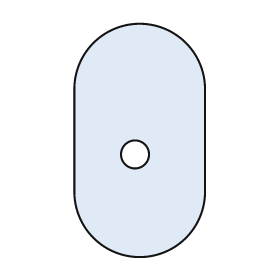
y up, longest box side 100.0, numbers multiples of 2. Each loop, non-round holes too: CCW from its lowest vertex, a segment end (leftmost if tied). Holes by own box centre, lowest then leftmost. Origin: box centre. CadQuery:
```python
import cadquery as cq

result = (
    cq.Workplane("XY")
    .moveTo(-28.0, -22.0)
    .threePointArc((0.0, -50.0), (28.0, -22.0))
    .lineTo(28.0, 22.0)
    .threePointArc((0.0, 50.0), (-28.0, 22.0))
    .close()
    .moveTo(-2.0, -6.0)
    .circle(6.0)
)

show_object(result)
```